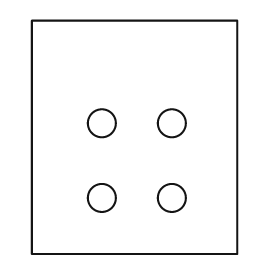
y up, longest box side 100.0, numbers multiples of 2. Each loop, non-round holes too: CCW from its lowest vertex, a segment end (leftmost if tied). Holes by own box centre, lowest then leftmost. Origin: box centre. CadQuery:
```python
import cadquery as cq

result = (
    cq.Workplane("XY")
    .moveTo(-44.0, -50.0)
    .lineTo(44.0, -50.0)
    .lineTo(44.0, 50.0)
    .lineTo(-44.0, 50.0)
    .close()
    .moveTo(-14.0, -26.0)
    .circle(6.0)
    .moveTo(16.0, -26.0)
    .circle(6.0)
    .moveTo(-14.0, 6.0)
    .circle(6.0)
    .moveTo(16.0, 6.0)
    .circle(6.0)
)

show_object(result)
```